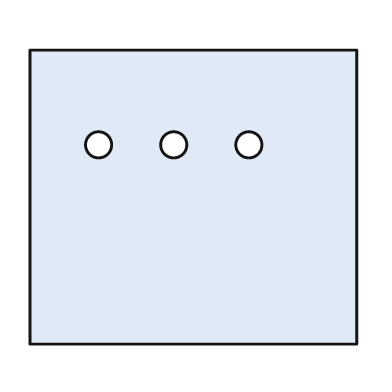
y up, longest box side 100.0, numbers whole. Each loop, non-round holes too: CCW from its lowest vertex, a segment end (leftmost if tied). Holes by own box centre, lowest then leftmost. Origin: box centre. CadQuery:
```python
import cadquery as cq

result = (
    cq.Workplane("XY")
    .moveTo(-50.0, -45.0)
    .lineTo(50.0, -45.0)
    .lineTo(50.0, 45.0)
    .lineTo(-50.0, 45.0)
    .close()
    .moveTo(-29.0, 16.0)
    .circle(4.0)
    .moveTo(-6.0, 16.0)
    .circle(4.0)
    .moveTo(17.0, 16.0)
    .circle(4.0)
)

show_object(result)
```